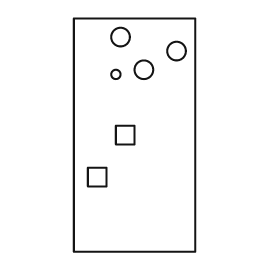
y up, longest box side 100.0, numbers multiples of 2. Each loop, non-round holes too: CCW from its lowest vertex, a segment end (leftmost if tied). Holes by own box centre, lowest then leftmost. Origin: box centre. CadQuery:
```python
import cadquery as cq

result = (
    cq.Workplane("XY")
    .moveTo(-26.0, -50.0)
    .lineTo(26.0, -50.0)
    .lineTo(26.0, 50.0)
    .lineTo(-26.0, 50.0)
    .close()
    .moveTo(-20.0, -22.0)
    .lineTo(-12.0, -22.0)
    .lineTo(-12.0, -14.0)
    .lineTo(-20.0, -14.0)
    .close()
    .moveTo(-8.0, -4.0)
    .lineTo(0.0, -4.0)
    .lineTo(0.0, 4.0)
    .lineTo(-8.0, 4.0)
    .close()
    .moveTo(-8.0, 26.0)
    .circle(2.0)
    .moveTo(4.0, 28.0)
    .circle(4.0)
    .moveTo(18.0, 36.0)
    .circle(4.0)
    .moveTo(-6.0, 42.0)
    .circle(4.0)
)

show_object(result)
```